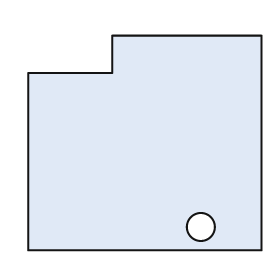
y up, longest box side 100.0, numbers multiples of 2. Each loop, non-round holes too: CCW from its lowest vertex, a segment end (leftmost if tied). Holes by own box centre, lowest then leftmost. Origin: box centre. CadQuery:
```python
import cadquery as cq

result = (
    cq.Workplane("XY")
    .moveTo(-50.0, -46.0)
    .lineTo(50.0, -46.0)
    .lineTo(50.0, 46.0)
    .lineTo(-14.0, 46.0)
    .lineTo(-14.0, 30.0)
    .lineTo(-50.0, 30.0)
    .close()
    .moveTo(24.0, -36.0)
    .circle(6.0)
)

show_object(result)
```